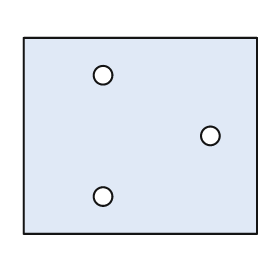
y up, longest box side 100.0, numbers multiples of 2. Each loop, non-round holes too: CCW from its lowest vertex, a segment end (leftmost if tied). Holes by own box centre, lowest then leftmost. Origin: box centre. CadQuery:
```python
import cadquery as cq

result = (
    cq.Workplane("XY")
    .moveTo(-50.0, -42.0)
    .lineTo(50.0, -42.0)
    .lineTo(50.0, 42.0)
    .lineTo(-50.0, 42.0)
    .close()
    .moveTo(-16.0, -26.0)
    .circle(4.0)
    .moveTo(30.0, 0.0)
    .circle(4.0)
    .moveTo(-16.0, 26.0)
    .circle(4.0)
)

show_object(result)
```